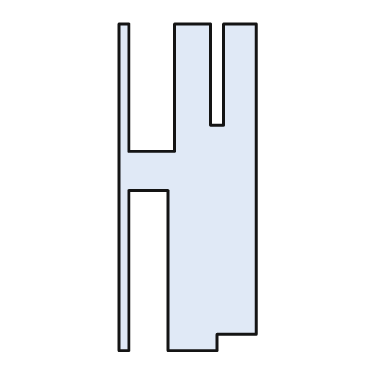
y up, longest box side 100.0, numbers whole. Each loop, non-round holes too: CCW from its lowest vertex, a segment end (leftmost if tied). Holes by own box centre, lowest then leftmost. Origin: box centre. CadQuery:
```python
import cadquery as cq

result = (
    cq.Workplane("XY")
    .moveTo(-21.0, -50.0)
    .lineTo(-18.0, -50.0)
    .lineTo(-18.0, -1.0)
    .lineTo(-6.0, -1.0)
    .lineTo(-6.0, -50.0)
    .lineTo(9.0, -50.0)
    .lineTo(9.0, -45.0)
    .lineTo(21.0, -45.0)
    .lineTo(21.0, 50.0)
    .lineTo(11.0, 50.0)
    .lineTo(11.0, 19.0)
    .lineTo(7.0, 19.0)
    .lineTo(7.0, 50.0)
    .lineTo(-4.0, 50.0)
    .lineTo(-4.0, 11.0)
    .lineTo(-18.0, 11.0)
    .lineTo(-18.0, 50.0)
    .lineTo(-21.0, 50.0)
    .close()
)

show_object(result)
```